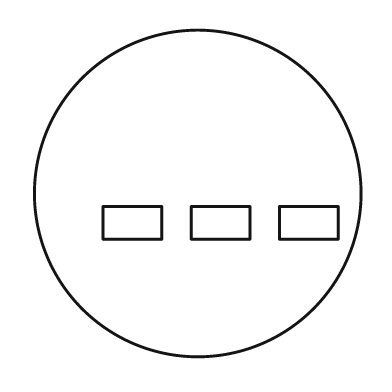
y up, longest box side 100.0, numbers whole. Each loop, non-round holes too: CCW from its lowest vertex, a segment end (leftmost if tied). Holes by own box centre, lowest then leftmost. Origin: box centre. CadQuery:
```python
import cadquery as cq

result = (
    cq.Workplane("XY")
    .moveTo(0.0, 0.0)
    .circle(50.0)
    .moveTo(-29.0, -14.0)
    .lineTo(-11.0, -14.0)
    .lineTo(-11.0, -4.0)
    .lineTo(-29.0, -4.0)
    .close()
    .moveTo(-2.0, -14.0)
    .lineTo(16.0, -14.0)
    .lineTo(16.0, -4.0)
    .lineTo(-2.0, -4.0)
    .close()
    .moveTo(25.0, -14.0)
    .lineTo(43.0, -14.0)
    .lineTo(43.0, -4.0)
    .lineTo(25.0, -4.0)
    .close()
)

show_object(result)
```